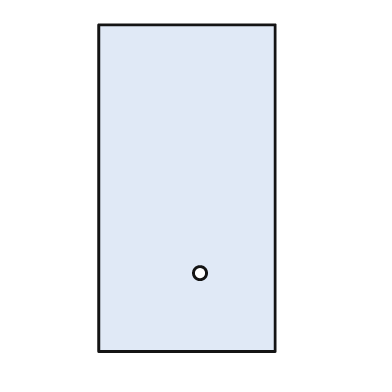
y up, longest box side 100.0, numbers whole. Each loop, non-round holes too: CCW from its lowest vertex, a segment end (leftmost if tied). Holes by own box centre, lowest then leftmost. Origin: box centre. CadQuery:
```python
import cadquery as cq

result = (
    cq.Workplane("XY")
    .moveTo(-27.0, -50.0)
    .lineTo(27.0, -50.0)
    .lineTo(27.0, 50.0)
    .lineTo(-27.0, 50.0)
    .close()
    .moveTo(4.0, -26.0)
    .circle(2.0)
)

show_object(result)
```